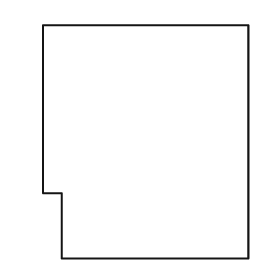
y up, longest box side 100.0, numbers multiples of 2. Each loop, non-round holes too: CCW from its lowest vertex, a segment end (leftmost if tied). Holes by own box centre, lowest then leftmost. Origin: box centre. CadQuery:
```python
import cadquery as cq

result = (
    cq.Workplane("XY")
    .moveTo(-36.0, -50.0)
    .lineTo(44.0, -50.0)
    .lineTo(44.0, 50.0)
    .lineTo(-44.0, 50.0)
    .lineTo(-44.0, -22.0)
    .lineTo(-36.0, -22.0)
    .close()
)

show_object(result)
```